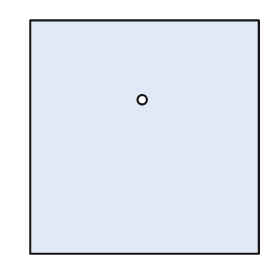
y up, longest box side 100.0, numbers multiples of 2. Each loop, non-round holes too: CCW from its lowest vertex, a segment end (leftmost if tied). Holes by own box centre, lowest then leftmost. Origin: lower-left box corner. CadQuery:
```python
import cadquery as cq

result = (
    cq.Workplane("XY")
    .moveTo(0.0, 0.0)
    .lineTo(98.0, 0.0)
    .lineTo(98.0, 100.0)
    .lineTo(0.0, 100.0)
    .close()
    .moveTo(48.0, 66.0)
    .circle(2.0)
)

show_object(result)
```